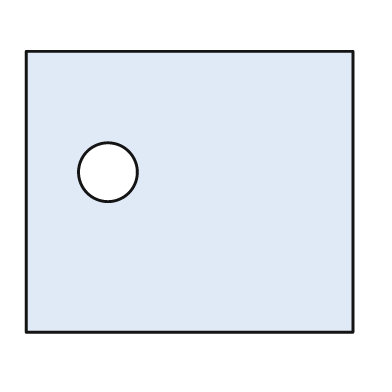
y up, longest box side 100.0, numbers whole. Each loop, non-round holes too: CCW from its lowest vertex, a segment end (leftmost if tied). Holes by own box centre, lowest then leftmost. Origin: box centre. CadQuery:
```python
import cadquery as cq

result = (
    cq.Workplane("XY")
    .moveTo(-50.0, -43.0)
    .lineTo(50.0, -43.0)
    .lineTo(50.0, 43.0)
    .lineTo(-50.0, 43.0)
    .close()
    .moveTo(-25.0, 6.0)
    .circle(9.0)
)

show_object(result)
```